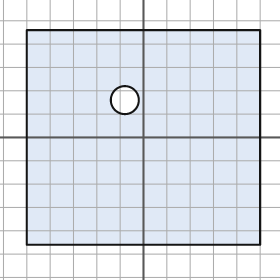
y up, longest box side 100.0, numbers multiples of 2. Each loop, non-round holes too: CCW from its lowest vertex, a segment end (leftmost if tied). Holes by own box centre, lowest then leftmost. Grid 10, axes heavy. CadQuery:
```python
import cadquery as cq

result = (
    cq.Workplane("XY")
    .moveTo(-50.0, -46.0)
    .lineTo(50.0, -46.0)
    .lineTo(50.0, 46.0)
    .lineTo(-50.0, 46.0)
    .close()
    .moveTo(-8.0, 16.0)
    .circle(6.0)
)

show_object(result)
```